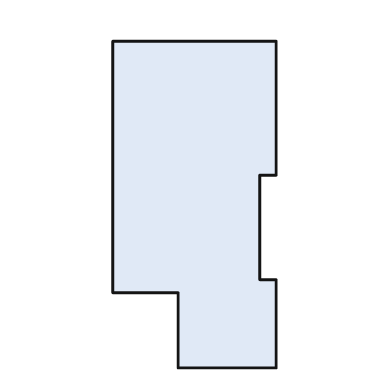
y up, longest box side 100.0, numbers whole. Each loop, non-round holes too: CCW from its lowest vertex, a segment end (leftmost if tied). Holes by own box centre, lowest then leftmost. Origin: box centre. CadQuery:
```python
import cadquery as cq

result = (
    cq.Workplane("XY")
    .moveTo(-5.0, -50.0)
    .lineTo(25.0, -50.0)
    .lineTo(25.0, -23.0)
    .lineTo(20.0, -23.0)
    .lineTo(20.0, 9.0)
    .lineTo(25.0, 9.0)
    .lineTo(25.0, 50.0)
    .lineTo(-25.0, 50.0)
    .lineTo(-25.0, -27.0)
    .lineTo(-5.0, -27.0)
    .close()
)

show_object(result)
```